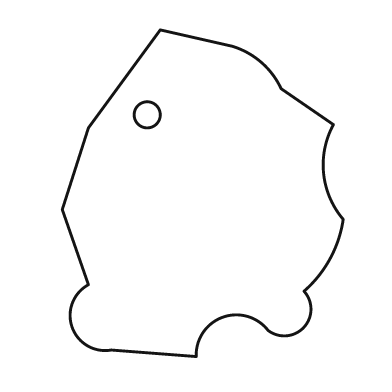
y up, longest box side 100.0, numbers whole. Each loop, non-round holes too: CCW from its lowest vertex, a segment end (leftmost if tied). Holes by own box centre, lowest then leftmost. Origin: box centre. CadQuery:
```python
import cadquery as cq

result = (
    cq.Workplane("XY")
    .moveTo(-2.0, -50.0)
    .threePointArc((6.0, -38.0), (20.0, -42.0))
    .threePointArc((31.0, -41.0), (31.0, -30.0))
    .threePointArc((39.0, -20.0), (43.0, -8.0))
    .threePointArc((37.0, 6.0), (40.0, 21.0))
    .lineTo(24.0, 32.0)
    .threePointArc((18.0, 40.0), (9.0, 45.0))
    .lineTo(-13.0, 50.0)
    .lineTo(-35.0, 20.0)
    .lineTo(-43.0, -5.0)
    .lineTo(-35.0, -28.0)
    .threePointArc((-40.0, -41.0), (-28.0, -48.0))
    .close()
    .moveTo(-17.0, 24.0)
    .circle(4.0)
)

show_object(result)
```